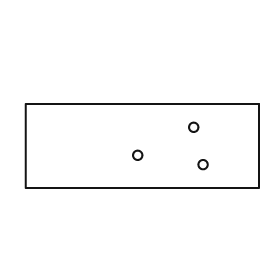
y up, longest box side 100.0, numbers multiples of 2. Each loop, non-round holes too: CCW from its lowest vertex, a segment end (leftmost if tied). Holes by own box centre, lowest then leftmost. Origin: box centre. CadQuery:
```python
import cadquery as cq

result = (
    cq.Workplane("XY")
    .moveTo(-50.0, -18.0)
    .lineTo(50.0, -18.0)
    .lineTo(50.0, 18.0)
    .lineTo(-50.0, 18.0)
    .close()
    .moveTo(26.0, -8.0)
    .circle(2.0)
    .moveTo(-2.0, -4.0)
    .circle(2.0)
    .moveTo(22.0, 8.0)
    .circle(2.0)
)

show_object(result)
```